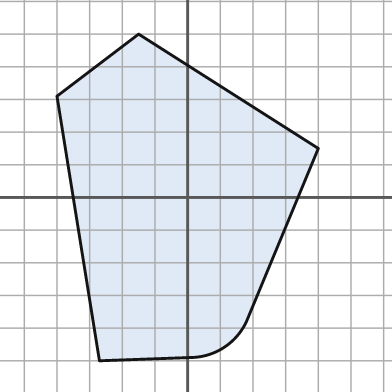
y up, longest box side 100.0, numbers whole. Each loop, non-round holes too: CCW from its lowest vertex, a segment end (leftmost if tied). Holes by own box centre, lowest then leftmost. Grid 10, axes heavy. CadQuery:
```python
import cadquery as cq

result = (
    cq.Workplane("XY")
    .moveTo(-27.0, -50.0)
    .lineTo(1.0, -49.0)
    .threePointArc((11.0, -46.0), (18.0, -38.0))
    .lineTo(40.0, 15.0)
    .lineTo(-15.0, 50.0)
    .lineTo(-40.0, 31.0)
    .close()
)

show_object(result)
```